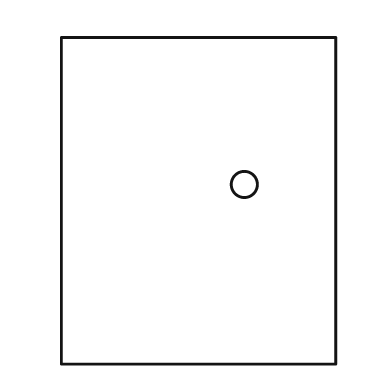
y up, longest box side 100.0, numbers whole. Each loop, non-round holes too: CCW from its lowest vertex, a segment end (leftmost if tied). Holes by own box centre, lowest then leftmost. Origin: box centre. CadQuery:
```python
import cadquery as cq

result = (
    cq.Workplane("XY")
    .moveTo(-42.0, -50.0)
    .lineTo(42.0, -50.0)
    .lineTo(42.0, 50.0)
    .lineTo(-42.0, 50.0)
    .close()
    .moveTo(14.0, 5.0)
    .circle(4.0)
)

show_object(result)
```